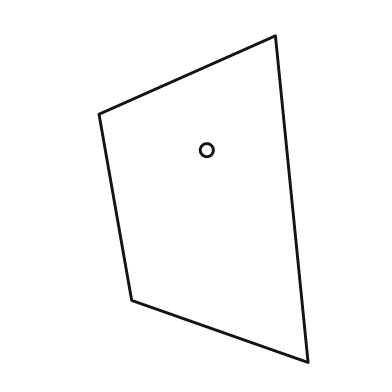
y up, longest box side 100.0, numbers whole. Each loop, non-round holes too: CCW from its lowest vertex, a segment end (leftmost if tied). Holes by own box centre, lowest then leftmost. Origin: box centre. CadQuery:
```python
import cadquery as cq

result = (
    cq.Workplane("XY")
    .moveTo(32.0, -50.0)
    .lineTo(22.0, 50.0)
    .lineTo(-32.0, 26.0)
    .lineTo(-22.0, -31.0)
    .close()
    .moveTo(1.0, 15.0)
    .circle(2.0)
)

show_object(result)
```